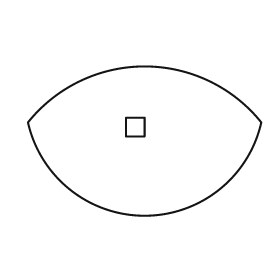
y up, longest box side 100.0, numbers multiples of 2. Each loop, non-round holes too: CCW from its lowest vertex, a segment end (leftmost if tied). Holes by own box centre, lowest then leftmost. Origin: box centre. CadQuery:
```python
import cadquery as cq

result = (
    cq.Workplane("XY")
    .moveTo(-50.0, 8.0)
    .threePointArc((0.0, -32.0), (50.0, 8.0))
    .threePointArc((0.0, 32.0), (-50.0, 8.0))
    .close()
    .moveTo(-8.0, 2.0)
    .lineTo(0.0, 2.0)
    .lineTo(0.0, 10.0)
    .lineTo(-8.0, 10.0)
    .close()
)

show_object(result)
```